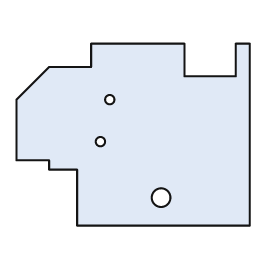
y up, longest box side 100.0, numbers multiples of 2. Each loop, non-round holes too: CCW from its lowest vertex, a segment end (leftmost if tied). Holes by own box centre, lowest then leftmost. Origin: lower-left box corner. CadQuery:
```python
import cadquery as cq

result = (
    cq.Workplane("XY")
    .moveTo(26.0, 0.0)
    .lineTo(100.0, 0.0)
    .lineTo(100.0, 78.0)
    .lineTo(94.0, 78.0)
    .lineTo(94.0, 64.0)
    .lineTo(72.0, 64.0)
    .lineTo(72.0, 78.0)
    .lineTo(32.0, 78.0)
    .lineTo(32.0, 68.0)
    .lineTo(14.0, 68.0)
    .lineTo(0.0, 54.0)
    .lineTo(0.0, 28.0)
    .lineTo(14.0, 28.0)
    .lineTo(14.0, 24.0)
    .lineTo(26.0, 24.0)
    .close()
    .moveTo(62.0, 12.0)
    .circle(4.0)
    .moveTo(36.0, 36.0)
    .circle(2.0)
    .moveTo(40.0, 54.0)
    .circle(2.0)
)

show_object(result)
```